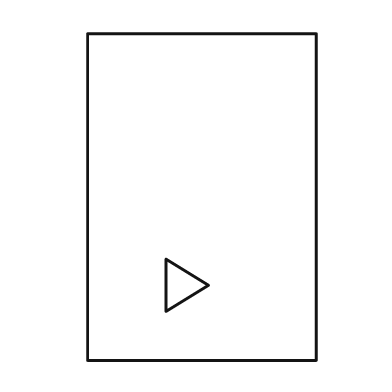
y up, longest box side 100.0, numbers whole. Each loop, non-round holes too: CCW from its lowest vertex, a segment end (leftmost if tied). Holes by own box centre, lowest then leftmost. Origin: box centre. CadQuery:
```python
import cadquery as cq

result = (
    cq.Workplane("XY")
    .moveTo(-35.0, -50.0)
    .lineTo(35.0, -50.0)
    .lineTo(35.0, 50.0)
    .lineTo(-35.0, 50.0)
    .close()
    .moveTo(-11.0, -35.0)
    .lineTo(2.0, -27.0)
    .lineTo(-11.0, -19.0)
    .close()
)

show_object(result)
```